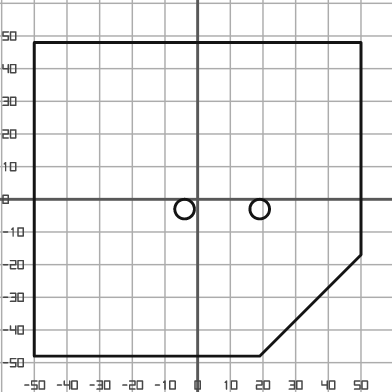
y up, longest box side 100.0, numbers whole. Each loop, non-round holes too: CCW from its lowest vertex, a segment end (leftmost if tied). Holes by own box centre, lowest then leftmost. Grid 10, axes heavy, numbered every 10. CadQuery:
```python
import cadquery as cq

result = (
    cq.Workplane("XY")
    .moveTo(-50.0, -48.0)
    .lineTo(19.0, -48.0)
    .lineTo(50.0, -17.0)
    .lineTo(50.0, 48.0)
    .lineTo(-50.0, 48.0)
    .close()
    .moveTo(-4.0, -3.0)
    .circle(3.0)
    .moveTo(19.0, -3.0)
    .circle(3.0)
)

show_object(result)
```